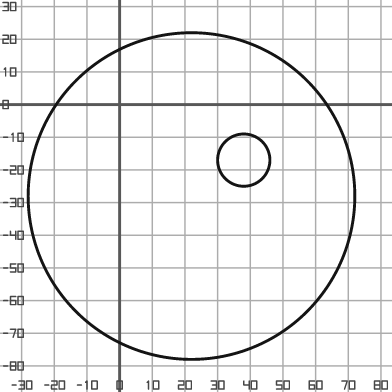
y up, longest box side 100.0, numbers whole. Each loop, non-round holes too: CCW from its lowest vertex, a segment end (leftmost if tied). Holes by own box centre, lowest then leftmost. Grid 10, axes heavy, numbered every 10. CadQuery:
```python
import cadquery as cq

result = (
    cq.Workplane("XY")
    .moveTo(22.0, -28.0)
    .circle(50.0)
    .moveTo(38.0, -17.0)
    .circle(8.0)
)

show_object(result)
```